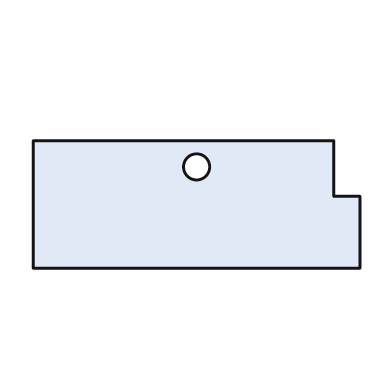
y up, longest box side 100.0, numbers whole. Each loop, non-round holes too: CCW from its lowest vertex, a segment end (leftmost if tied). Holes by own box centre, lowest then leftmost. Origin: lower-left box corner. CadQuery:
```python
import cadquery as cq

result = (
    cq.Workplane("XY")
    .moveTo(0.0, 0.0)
    .lineTo(100.0, 0.0)
    .lineTo(100.0, 22.0)
    .lineTo(92.0, 22.0)
    .lineTo(92.0, 39.0)
    .lineTo(0.0, 39.0)
    .close()
    .moveTo(50.0, 31.0)
    .circle(4.0)
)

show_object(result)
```